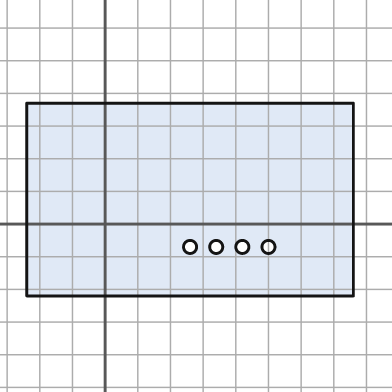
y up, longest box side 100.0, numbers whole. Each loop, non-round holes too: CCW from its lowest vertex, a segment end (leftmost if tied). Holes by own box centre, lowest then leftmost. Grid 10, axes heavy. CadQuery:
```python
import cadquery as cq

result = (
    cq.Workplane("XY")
    .moveTo(-24.0, -22.0)
    .lineTo(76.0, -22.0)
    .lineTo(76.0, 37.0)
    .lineTo(-24.0, 37.0)
    .close()
    .moveTo(26.0, -7.0)
    .circle(2.0)
    .moveTo(34.0, -7.0)
    .circle(2.0)
    .moveTo(42.0, -7.0)
    .circle(2.0)
    .moveTo(50.0, -7.0)
    .circle(2.0)
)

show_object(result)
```